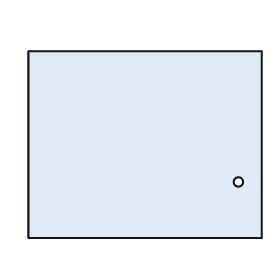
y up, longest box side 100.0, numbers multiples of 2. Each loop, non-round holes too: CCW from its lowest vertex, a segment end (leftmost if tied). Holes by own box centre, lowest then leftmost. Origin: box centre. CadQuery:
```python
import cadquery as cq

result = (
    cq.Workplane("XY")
    .moveTo(-50.0, -40.0)
    .lineTo(50.0, -40.0)
    .lineTo(50.0, 40.0)
    .lineTo(-50.0, 40.0)
    .close()
    .moveTo(40.0, -16.0)
    .circle(2.0)
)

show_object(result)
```